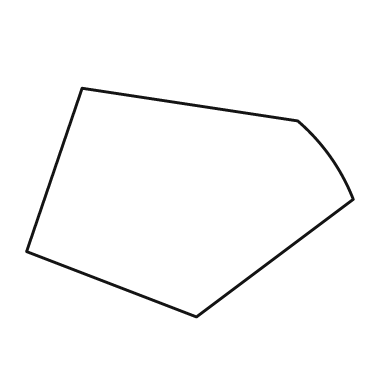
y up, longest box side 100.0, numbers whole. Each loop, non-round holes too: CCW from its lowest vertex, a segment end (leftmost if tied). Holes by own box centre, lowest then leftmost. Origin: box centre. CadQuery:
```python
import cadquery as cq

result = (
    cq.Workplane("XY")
    .moveTo(2.0, -35.0)
    .lineTo(50.0, 1.0)
    .threePointArc((43.0, 14.0), (33.0, 25.0))
    .lineTo(-33.0, 35.0)
    .lineTo(-50.0, -15.0)
    .close()
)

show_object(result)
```